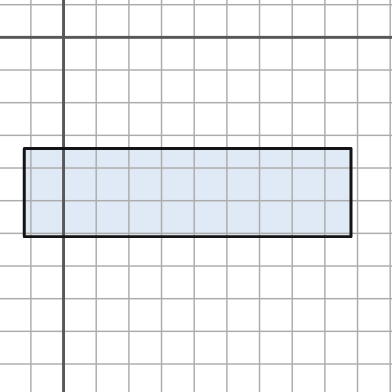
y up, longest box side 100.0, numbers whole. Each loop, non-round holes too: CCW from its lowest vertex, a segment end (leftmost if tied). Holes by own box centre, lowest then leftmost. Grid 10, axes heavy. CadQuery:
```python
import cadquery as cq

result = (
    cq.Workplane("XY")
    .moveTo(-12.0, -61.0)
    .lineTo(88.0, -61.0)
    .lineTo(88.0, -34.0)
    .lineTo(-12.0, -34.0)
    .close()
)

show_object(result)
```